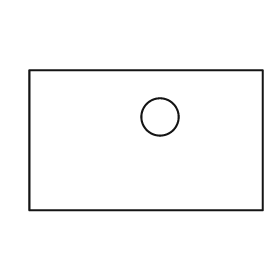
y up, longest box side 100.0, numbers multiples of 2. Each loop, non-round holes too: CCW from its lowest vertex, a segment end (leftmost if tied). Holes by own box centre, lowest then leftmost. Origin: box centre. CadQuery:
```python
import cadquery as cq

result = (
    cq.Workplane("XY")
    .moveTo(-50.0, -30.0)
    .lineTo(50.0, -30.0)
    .lineTo(50.0, 30.0)
    .lineTo(-50.0, 30.0)
    .close()
    .moveTo(6.0, 10.0)
    .circle(8.0)
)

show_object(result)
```